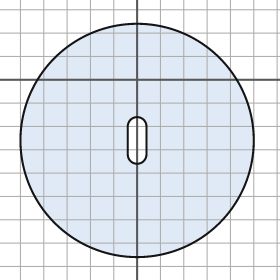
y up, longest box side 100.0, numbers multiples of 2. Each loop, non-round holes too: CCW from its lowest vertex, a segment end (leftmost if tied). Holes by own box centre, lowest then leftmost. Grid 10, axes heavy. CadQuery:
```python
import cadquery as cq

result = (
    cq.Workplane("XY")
    .moveTo(0.0, -26.0)
    .circle(50.0)
    .moveTo(-4.0, -32.0)
    .threePointArc((0.0, -36.0), (4.0, -32.0))
    .lineTo(4.0, -20.0)
    .threePointArc((0.0, -16.0), (-4.0, -20.0))
    .close()
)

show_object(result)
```